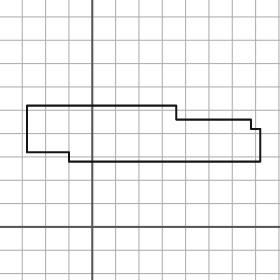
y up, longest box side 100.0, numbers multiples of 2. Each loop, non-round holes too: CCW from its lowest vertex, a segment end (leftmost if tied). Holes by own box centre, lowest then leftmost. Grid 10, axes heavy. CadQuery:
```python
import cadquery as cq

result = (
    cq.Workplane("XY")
    .moveTo(-10.0, 28.0)
    .lineTo(72.0, 28.0)
    .lineTo(72.0, 42.0)
    .lineTo(68.0, 42.0)
    .lineTo(68.0, 46.0)
    .lineTo(36.0, 46.0)
    .lineTo(36.0, 52.0)
    .lineTo(-28.0, 52.0)
    .lineTo(-28.0, 32.0)
    .lineTo(-10.0, 32.0)
    .close()
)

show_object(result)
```